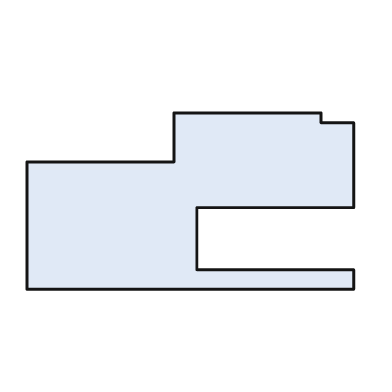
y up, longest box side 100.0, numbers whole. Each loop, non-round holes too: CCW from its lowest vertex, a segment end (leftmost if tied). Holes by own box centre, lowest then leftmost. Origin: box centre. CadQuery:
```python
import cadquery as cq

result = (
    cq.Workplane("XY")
    .moveTo(-50.0, -27.0)
    .lineTo(50.0, -27.0)
    .lineTo(50.0, -21.0)
    .lineTo(2.0, -21.0)
    .lineTo(2.0, -2.0)
    .lineTo(50.0, -2.0)
    .lineTo(50.0, 24.0)
    .lineTo(40.0, 24.0)
    .lineTo(40.0, 27.0)
    .lineTo(-5.0, 27.0)
    .lineTo(-5.0, 12.0)
    .lineTo(-50.0, 12.0)
    .close()
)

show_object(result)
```